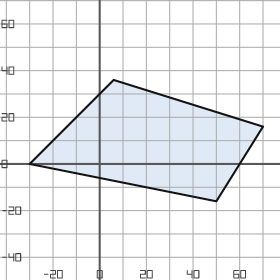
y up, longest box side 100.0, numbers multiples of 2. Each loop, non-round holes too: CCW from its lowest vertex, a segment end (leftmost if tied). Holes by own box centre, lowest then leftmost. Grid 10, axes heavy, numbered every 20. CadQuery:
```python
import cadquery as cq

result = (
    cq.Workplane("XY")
    .moveTo(50.0, -16.0)
    .lineTo(70.0, 16.0)
    .lineTo(6.0, 36.0)
    .lineTo(-30.0, 0.0)
    .close()
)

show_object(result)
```